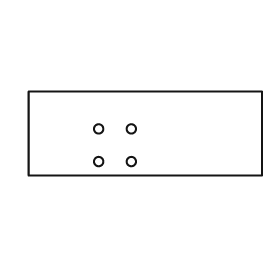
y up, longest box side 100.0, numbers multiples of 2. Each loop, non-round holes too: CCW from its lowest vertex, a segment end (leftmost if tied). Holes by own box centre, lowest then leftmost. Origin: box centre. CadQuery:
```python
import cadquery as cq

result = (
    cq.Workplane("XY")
    .moveTo(-50.0, -18.0)
    .lineTo(50.0, -18.0)
    .lineTo(50.0, 18.0)
    .lineTo(-50.0, 18.0)
    .close()
    .moveTo(-20.0, -12.0)
    .circle(2.0)
    .moveTo(-6.0, -12.0)
    .circle(2.0)
    .moveTo(-20.0, 2.0)
    .circle(2.0)
    .moveTo(-6.0, 2.0)
    .circle(2.0)
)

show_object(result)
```